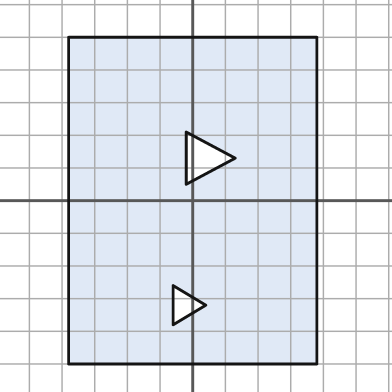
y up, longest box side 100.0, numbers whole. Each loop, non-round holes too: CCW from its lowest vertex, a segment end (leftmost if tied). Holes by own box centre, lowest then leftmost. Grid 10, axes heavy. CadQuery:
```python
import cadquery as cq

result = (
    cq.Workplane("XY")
    .moveTo(-38.0, -50.0)
    .lineTo(38.0, -50.0)
    .lineTo(38.0, 50.0)
    .lineTo(-38.0, 50.0)
    .close()
    .moveTo(-6.0, -38.0)
    .lineTo(4.0, -32.0)
    .lineTo(-6.0, -26.0)
    .close()
    .moveTo(-2.0, 5.0)
    .lineTo(13.0, 13.0)
    .lineTo(-2.0, 21.0)
    .close()
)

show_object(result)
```